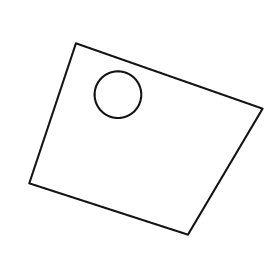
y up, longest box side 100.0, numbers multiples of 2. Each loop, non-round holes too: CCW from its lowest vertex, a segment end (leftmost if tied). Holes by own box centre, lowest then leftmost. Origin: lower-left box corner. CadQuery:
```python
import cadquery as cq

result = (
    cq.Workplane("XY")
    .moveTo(68.0, 0.0)
    .lineTo(100.0, 54.0)
    .lineTo(20.0, 82.0)
    .lineTo(0.0, 22.0)
    .close()
    .moveTo(38.0, 60.0)
    .circle(10.0)
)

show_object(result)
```